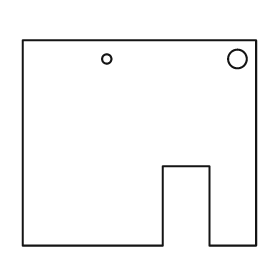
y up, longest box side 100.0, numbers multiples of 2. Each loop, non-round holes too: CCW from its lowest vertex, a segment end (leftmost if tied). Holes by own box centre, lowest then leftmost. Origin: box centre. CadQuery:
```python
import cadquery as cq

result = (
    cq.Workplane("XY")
    .moveTo(-50.0, -44.0)
    .lineTo(10.0, -44.0)
    .lineTo(10.0, -10.0)
    .lineTo(30.0, -10.0)
    .lineTo(30.0, -44.0)
    .lineTo(50.0, -44.0)
    .lineTo(50.0, 44.0)
    .lineTo(-50.0, 44.0)
    .close()
    .moveTo(-14.0, 36.0)
    .circle(2.0)
    .moveTo(42.0, 36.0)
    .circle(4.0)
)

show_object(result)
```